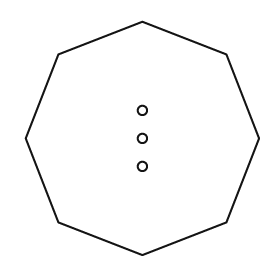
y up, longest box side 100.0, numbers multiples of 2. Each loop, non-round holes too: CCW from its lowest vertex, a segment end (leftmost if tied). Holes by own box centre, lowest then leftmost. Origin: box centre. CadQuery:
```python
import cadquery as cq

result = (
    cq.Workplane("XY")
    .moveTo(0.0, -50.0)
    .lineTo(36.0, -36.0)
    .lineTo(50.0, 0.0)
    .lineTo(36.0, 36.0)
    .lineTo(0.0, 50.0)
    .lineTo(-36.0, 36.0)
    .lineTo(-50.0, 0.0)
    .lineTo(-36.0, -36.0)
    .close()
    .moveTo(0.0, -12.0)
    .circle(2.0)
    .moveTo(0.0, 0.0)
    .circle(2.0)
    .moveTo(0.0, 12.0)
    .circle(2.0)
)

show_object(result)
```